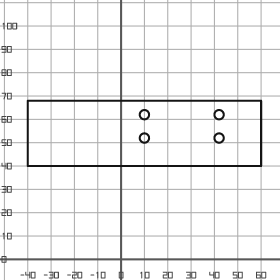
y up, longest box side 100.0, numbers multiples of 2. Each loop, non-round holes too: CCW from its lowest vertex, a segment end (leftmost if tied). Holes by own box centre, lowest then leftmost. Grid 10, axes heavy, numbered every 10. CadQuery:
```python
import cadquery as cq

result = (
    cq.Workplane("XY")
    .moveTo(-40.0, 40.0)
    .lineTo(60.0, 40.0)
    .lineTo(60.0, 68.0)
    .lineTo(-40.0, 68.0)
    .close()
    .moveTo(10.0, 52.0)
    .circle(2.0)
    .moveTo(42.0, 52.0)
    .circle(2.0)
    .moveTo(10.0, 62.0)
    .circle(2.0)
    .moveTo(42.0, 62.0)
    .circle(2.0)
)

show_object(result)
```